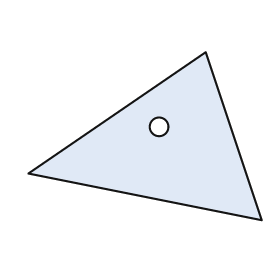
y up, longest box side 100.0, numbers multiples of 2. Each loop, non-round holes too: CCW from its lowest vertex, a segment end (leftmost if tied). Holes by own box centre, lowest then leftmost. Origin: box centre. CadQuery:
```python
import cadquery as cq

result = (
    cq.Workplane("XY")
    .moveTo(50.0, -36.0)
    .lineTo(26.0, 36.0)
    .lineTo(-50.0, -16.0)
    .close()
    .moveTo(6.0, 4.0)
    .circle(4.0)
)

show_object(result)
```